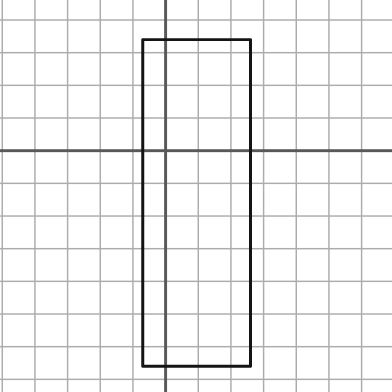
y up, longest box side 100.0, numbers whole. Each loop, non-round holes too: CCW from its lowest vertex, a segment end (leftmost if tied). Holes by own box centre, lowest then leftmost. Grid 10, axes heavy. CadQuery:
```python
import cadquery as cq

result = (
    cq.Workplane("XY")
    .moveTo(-7.0, -66.0)
    .lineTo(26.0, -66.0)
    .lineTo(26.0, 34.0)
    .lineTo(-7.0, 34.0)
    .close()
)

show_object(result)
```